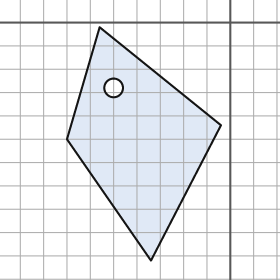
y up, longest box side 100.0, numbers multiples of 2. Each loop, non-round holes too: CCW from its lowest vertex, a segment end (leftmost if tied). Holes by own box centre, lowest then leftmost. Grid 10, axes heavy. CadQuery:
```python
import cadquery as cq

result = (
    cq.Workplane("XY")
    .moveTo(-34.0, -102.0)
    .lineTo(-4.0, -44.0)
    .lineTo(-56.0, -2.0)
    .lineTo(-70.0, -50.0)
    .close()
    .moveTo(-50.0, -28.0)
    .circle(4.0)
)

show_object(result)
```